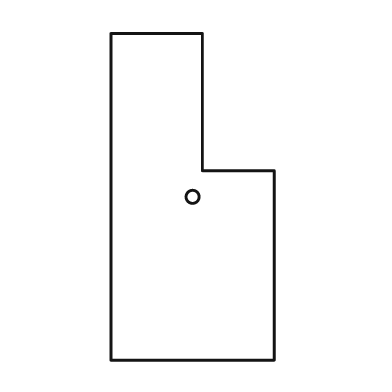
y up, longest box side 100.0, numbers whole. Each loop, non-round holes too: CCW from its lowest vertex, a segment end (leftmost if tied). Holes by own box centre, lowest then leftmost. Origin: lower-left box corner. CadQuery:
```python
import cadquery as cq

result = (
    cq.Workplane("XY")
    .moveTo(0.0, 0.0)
    .lineTo(50.0, 0.0)
    .lineTo(50.0, 58.0)
    .lineTo(28.0, 58.0)
    .lineTo(28.0, 100.0)
    .lineTo(0.0, 100.0)
    .close()
    .moveTo(25.0, 50.0)
    .circle(2.0)
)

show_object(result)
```